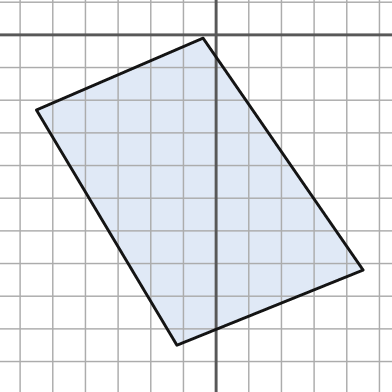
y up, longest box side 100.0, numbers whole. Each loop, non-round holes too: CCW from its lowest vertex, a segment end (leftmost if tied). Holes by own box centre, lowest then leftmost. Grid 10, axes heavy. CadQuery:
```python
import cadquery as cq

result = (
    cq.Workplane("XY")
    .moveTo(-12.0, -95.0)
    .lineTo(45.0, -72.0)
    .lineTo(-4.0, -1.0)
    .lineTo(-55.0, -23.0)
    .close()
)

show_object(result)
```